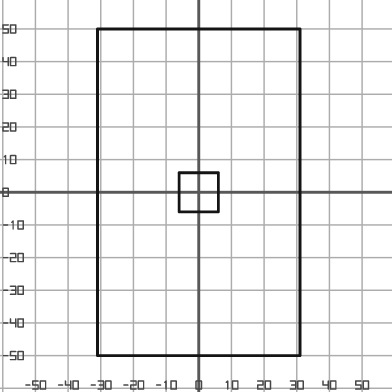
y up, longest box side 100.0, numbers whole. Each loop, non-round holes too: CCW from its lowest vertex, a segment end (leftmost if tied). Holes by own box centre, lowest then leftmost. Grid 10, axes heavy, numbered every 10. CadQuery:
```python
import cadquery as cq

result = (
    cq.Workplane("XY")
    .moveTo(-31.0, -50.0)
    .lineTo(31.0, -50.0)
    .lineTo(31.0, 50.0)
    .lineTo(-31.0, 50.0)
    .close()
    .moveTo(-6.0, -6.0)
    .lineTo(6.0, -6.0)
    .lineTo(6.0, 6.0)
    .lineTo(-6.0, 6.0)
    .close()
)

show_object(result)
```